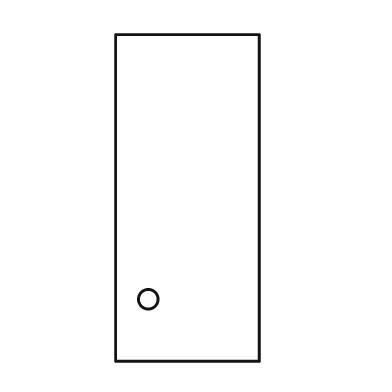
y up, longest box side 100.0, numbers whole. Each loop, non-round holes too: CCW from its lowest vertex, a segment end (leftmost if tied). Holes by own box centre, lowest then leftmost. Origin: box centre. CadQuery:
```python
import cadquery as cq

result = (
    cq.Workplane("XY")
    .moveTo(-22.0, -50.0)
    .lineTo(22.0, -50.0)
    .lineTo(22.0, 50.0)
    .lineTo(-22.0, 50.0)
    .close()
    .moveTo(-12.0, -31.0)
    .circle(3.0)
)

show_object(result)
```